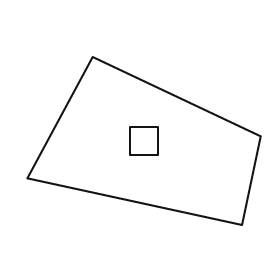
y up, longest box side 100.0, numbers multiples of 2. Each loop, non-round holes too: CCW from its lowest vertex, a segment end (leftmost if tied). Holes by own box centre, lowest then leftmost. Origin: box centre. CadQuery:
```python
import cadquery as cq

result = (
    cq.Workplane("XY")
    .moveTo(42.0, -36.0)
    .lineTo(50.0, 2.0)
    .lineTo(-22.0, 36.0)
    .lineTo(-50.0, -16.0)
    .close()
    .moveTo(-6.0, -6.0)
    .lineTo(6.0, -6.0)
    .lineTo(6.0, 6.0)
    .lineTo(-6.0, 6.0)
    .close()
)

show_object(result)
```